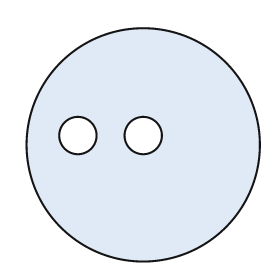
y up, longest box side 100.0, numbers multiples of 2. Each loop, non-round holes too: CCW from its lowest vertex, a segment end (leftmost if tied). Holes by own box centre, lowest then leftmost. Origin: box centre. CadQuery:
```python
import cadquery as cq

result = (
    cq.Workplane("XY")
    .moveTo(0.0, 0.0)
    .circle(50.0)
    .moveTo(-28.0, 4.0)
    .circle(8.0)
    .moveTo(0.0, 4.0)
    .circle(8.0)
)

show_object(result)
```